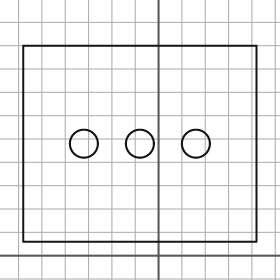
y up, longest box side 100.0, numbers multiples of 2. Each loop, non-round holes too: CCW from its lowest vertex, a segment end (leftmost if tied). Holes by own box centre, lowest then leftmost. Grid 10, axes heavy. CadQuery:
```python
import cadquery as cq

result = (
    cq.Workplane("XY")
    .moveTo(-58.0, 6.0)
    .lineTo(42.0, 6.0)
    .lineTo(42.0, 90.0)
    .lineTo(-58.0, 90.0)
    .close()
    .moveTo(-32.0, 48.0)
    .circle(6.0)
    .moveTo(-8.0, 48.0)
    .circle(6.0)
    .moveTo(16.0, 48.0)
    .circle(6.0)
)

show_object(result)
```